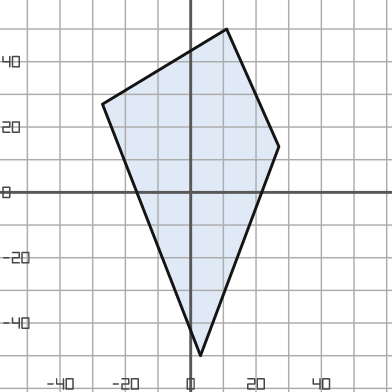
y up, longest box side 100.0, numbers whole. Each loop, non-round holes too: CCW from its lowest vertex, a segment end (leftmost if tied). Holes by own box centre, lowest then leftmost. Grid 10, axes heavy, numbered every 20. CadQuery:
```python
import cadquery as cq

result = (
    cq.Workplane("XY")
    .moveTo(3.0, -50.0)
    .lineTo(27.0, 14.0)
    .lineTo(11.0, 50.0)
    .lineTo(-27.0, 27.0)
    .close()
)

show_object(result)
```